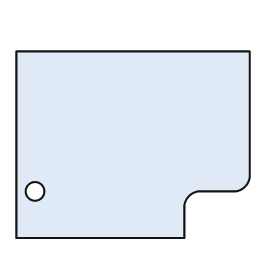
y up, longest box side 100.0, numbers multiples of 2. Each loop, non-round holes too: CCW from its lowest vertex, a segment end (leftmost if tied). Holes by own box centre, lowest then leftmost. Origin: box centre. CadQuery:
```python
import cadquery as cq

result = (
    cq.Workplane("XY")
    .moveTo(-50.0, -40.0)
    .lineTo(22.0, -40.0)
    .lineTo(22.0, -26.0)
    .threePointArc((24.0, -22.0), (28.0, -20.0))
    .lineTo(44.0, -20.0)
    .threePointArc((48.0, -18.0), (50.0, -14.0))
    .lineTo(50.0, 40.0)
    .lineTo(-50.0, 40.0)
    .close()
    .moveTo(-42.0, -20.0)
    .circle(4.0)
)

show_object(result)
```